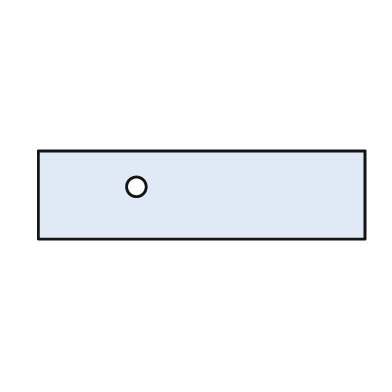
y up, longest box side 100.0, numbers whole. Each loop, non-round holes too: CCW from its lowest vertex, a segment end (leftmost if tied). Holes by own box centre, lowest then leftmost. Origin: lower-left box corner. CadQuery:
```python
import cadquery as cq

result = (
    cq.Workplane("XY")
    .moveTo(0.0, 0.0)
    .lineTo(100.0, 0.0)
    .lineTo(100.0, 27.0)
    .lineTo(0.0, 27.0)
    .close()
    .moveTo(30.0, 16.0)
    .circle(3.0)
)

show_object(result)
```